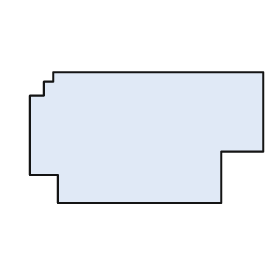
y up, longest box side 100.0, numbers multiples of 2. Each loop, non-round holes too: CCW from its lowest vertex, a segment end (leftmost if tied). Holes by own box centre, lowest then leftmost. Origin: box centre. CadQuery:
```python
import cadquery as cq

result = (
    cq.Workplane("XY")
    .moveTo(-38.0, -28.0)
    .lineTo(32.0, -28.0)
    .lineTo(32.0, -6.0)
    .lineTo(50.0, -6.0)
    .lineTo(50.0, 28.0)
    .lineTo(-40.0, 28.0)
    .lineTo(-40.0, 24.0)
    .lineTo(-44.0, 24.0)
    .lineTo(-44.0, 18.0)
    .lineTo(-50.0, 18.0)
    .lineTo(-50.0, -16.0)
    .lineTo(-38.0, -16.0)
    .close()
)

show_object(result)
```